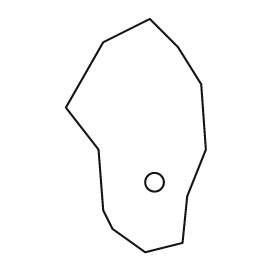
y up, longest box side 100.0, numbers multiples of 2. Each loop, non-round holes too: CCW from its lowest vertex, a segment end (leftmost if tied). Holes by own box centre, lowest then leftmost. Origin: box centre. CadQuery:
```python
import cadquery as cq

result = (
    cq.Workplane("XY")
    .moveTo(4.0, -50.0)
    .lineTo(20.0, -46.0)
    .lineTo(22.0, -26.0)
    .lineTo(30.0, -6.0)
    .lineTo(28.0, 22.0)
    .lineTo(18.0, 38.0)
    .lineTo(6.0, 50.0)
    .lineTo(-14.0, 40.0)
    .lineTo(-30.0, 12.0)
    .lineTo(-16.0, -6.0)
    .lineTo(-14.0, -32.0)
    .lineTo(-10.0, -40.0)
    .close()
    .moveTo(8.0, -20.0)
    .circle(4.0)
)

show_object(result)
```